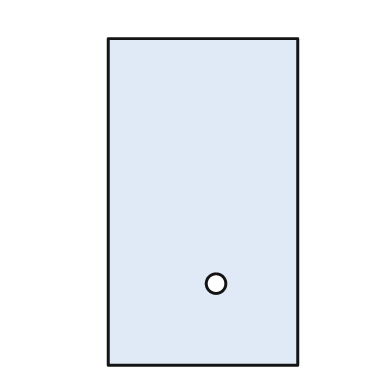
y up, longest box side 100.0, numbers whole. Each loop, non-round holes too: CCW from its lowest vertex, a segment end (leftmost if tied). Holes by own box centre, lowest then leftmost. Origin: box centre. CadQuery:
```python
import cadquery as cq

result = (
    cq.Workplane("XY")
    .moveTo(-29.0, -50.0)
    .lineTo(29.0, -50.0)
    .lineTo(29.0, 50.0)
    .lineTo(-29.0, 50.0)
    .close()
    .moveTo(4.0, -25.0)
    .circle(3.0)
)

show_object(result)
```